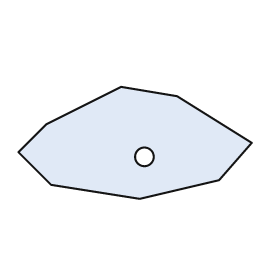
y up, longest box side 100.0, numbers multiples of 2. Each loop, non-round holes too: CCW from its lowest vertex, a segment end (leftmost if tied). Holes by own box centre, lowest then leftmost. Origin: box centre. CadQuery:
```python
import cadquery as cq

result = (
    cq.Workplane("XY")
    .moveTo(2.0, -24.0)
    .lineTo(36.0, -16.0)
    .lineTo(50.0, 0.0)
    .lineTo(18.0, 20.0)
    .lineTo(-6.0, 24.0)
    .lineTo(-38.0, 8.0)
    .lineTo(-50.0, -4.0)
    .lineTo(-36.0, -18.0)
    .close()
    .moveTo(4.0, -6.0)
    .circle(4.0)
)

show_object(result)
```